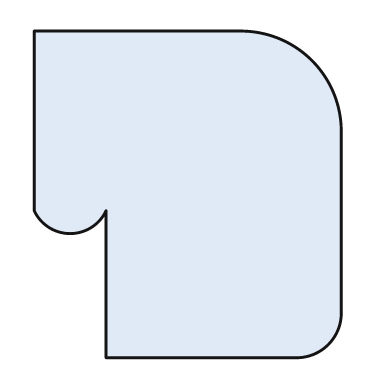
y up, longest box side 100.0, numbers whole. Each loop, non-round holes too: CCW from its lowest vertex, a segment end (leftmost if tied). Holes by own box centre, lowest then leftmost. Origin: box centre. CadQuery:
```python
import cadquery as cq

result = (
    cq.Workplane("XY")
    .moveTo(-25.0, -50.0)
    .lineTo(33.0, -50.0)
    .threePointArc((43.0, -46.0), (47.0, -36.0))
    .lineTo(47.0, 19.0)
    .threePointArc((38.0, 41.0), (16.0, 50.0))
    .lineTo(-47.0, 50.0)
    .lineTo(-47.0, -5.0)
    .threePointArc((-36.0, -12.0), (-25.0, -5.0))
    .close()
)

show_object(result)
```